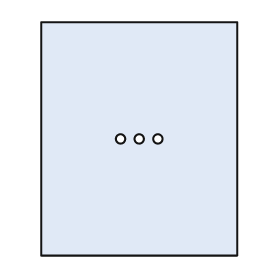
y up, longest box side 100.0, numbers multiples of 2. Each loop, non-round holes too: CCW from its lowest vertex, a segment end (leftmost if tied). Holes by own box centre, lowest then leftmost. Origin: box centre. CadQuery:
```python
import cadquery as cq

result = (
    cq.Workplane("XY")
    .moveTo(-42.0, -50.0)
    .lineTo(42.0, -50.0)
    .lineTo(42.0, 50.0)
    .lineTo(-42.0, 50.0)
    .close()
    .moveTo(-8.0, 0.0)
    .circle(2.0)
    .moveTo(0.0, 0.0)
    .circle(2.0)
    .moveTo(8.0, 0.0)
    .circle(2.0)
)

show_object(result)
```